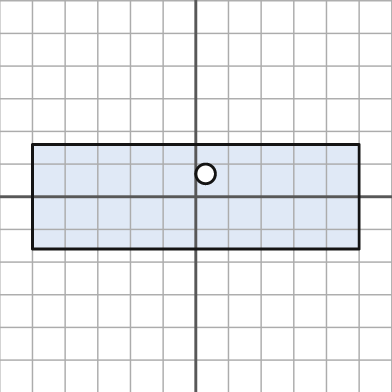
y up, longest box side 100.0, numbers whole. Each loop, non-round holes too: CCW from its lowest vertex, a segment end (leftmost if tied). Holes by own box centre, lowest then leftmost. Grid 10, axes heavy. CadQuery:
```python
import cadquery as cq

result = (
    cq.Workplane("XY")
    .moveTo(-50.0, -16.0)
    .lineTo(50.0, -16.0)
    .lineTo(50.0, 16.0)
    .lineTo(-50.0, 16.0)
    .close()
    .moveTo(3.0, 7.0)
    .circle(3.0)
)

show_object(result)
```